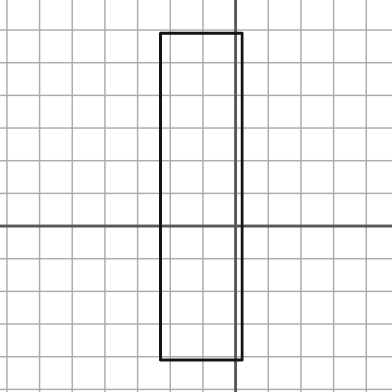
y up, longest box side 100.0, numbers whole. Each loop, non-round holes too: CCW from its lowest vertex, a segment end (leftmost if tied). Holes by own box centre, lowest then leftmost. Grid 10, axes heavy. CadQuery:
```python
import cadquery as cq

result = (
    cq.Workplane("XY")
    .moveTo(-23.0, -41.0)
    .lineTo(2.0, -41.0)
    .lineTo(2.0, 59.0)
    .lineTo(-23.0, 59.0)
    .close()
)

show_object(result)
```